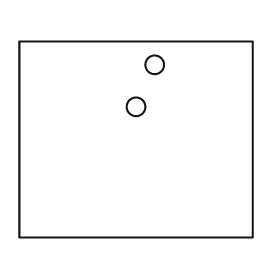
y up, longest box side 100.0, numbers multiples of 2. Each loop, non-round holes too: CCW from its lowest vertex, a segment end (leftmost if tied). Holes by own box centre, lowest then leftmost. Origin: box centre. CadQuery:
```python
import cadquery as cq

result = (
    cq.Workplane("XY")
    .moveTo(-50.0, -42.0)
    .lineTo(50.0, -42.0)
    .lineTo(50.0, 42.0)
    .lineTo(-50.0, 42.0)
    .close()
    .moveTo(0.0, 14.0)
    .circle(4.0)
    .moveTo(8.0, 32.0)
    .circle(4.0)
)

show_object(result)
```